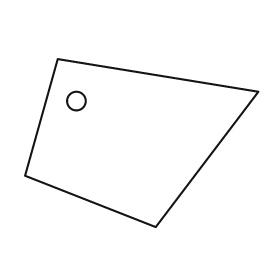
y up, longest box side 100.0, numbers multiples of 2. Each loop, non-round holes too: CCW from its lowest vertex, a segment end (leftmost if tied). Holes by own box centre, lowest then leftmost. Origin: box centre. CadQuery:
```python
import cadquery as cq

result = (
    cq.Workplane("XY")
    .moveTo(6.0, -36.0)
    .lineTo(50.0, 22.0)
    .lineTo(-36.0, 36.0)
    .lineTo(-50.0, -14.0)
    .close()
    .moveTo(-28.0, 18.0)
    .circle(4.0)
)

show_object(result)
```